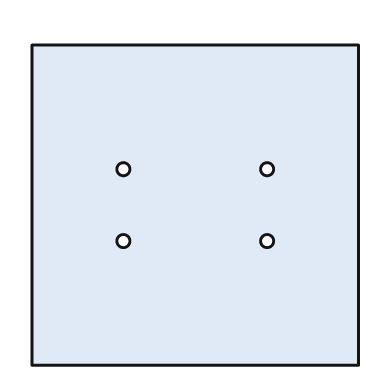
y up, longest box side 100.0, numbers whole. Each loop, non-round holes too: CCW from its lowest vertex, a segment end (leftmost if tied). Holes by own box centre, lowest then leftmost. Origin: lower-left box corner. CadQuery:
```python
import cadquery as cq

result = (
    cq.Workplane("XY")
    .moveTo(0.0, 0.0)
    .lineTo(100.0, 0.0)
    .lineTo(100.0, 98.0)
    .lineTo(0.0, 98.0)
    .close()
    .moveTo(28.0, 38.0)
    .circle(2.0)
    .moveTo(72.0, 38.0)
    .circle(2.0)
    .moveTo(28.0, 60.0)
    .circle(2.0)
    .moveTo(72.0, 60.0)
    .circle(2.0)
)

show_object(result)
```